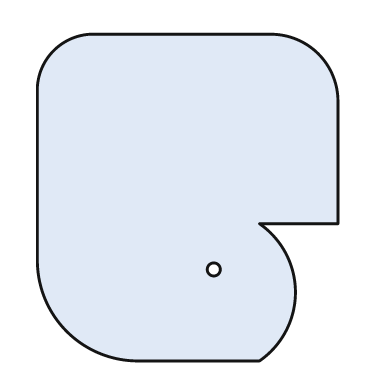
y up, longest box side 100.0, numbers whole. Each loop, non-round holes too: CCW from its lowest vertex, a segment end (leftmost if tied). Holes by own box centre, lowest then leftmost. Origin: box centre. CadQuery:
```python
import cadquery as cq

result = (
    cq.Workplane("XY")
    .moveTo(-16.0, -50.0)
    .lineTo(22.0, -50.0)
    .threePointArc((33.0, -29.0), (22.0, -8.0))
    .lineTo(46.0, -8.0)
    .lineTo(46.0, 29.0)
    .threePointArc((40.0, 44.0), (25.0, 50.0))
    .lineTo(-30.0, 50.0)
    .threePointArc((-41.0, 45.0), (-46.0, 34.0))
    .lineTo(-46.0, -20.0)
    .threePointArc((-37.0, -41.0), (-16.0, -50.0))
    .close()
    .moveTo(8.0, -22.0)
    .circle(2.0)
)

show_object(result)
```